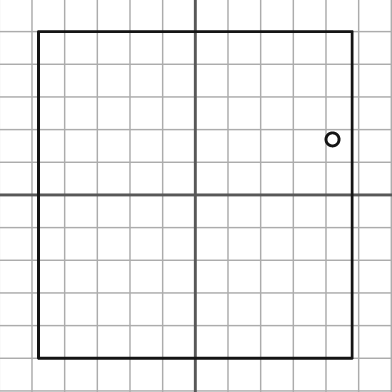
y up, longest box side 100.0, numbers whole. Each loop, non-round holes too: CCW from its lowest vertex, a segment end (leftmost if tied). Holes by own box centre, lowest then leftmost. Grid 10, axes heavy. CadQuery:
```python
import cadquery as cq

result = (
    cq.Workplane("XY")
    .moveTo(-48.0, -50.0)
    .lineTo(48.0, -50.0)
    .lineTo(48.0, 50.0)
    .lineTo(-48.0, 50.0)
    .close()
    .moveTo(42.0, 17.0)
    .circle(2.0)
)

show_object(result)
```